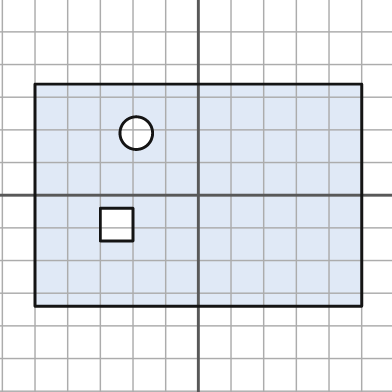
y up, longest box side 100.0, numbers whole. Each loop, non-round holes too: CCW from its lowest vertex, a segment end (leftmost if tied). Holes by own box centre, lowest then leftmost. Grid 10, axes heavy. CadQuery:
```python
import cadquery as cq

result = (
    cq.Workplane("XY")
    .moveTo(-50.0, -34.0)
    .lineTo(50.0, -34.0)
    .lineTo(50.0, 34.0)
    .lineTo(-50.0, 34.0)
    .close()
    .moveTo(-30.0, -14.0)
    .lineTo(-20.0, -14.0)
    .lineTo(-20.0, -4.0)
    .lineTo(-30.0, -4.0)
    .close()
    .moveTo(-19.0, 19.0)
    .circle(5.0)
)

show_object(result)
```